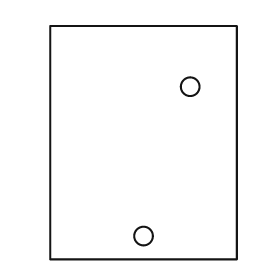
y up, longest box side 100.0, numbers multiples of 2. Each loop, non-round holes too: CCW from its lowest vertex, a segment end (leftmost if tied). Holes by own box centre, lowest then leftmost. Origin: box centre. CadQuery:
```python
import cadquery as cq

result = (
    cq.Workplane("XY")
    .moveTo(-40.0, -50.0)
    .lineTo(40.0, -50.0)
    .lineTo(40.0, 50.0)
    .lineTo(-40.0, 50.0)
    .close()
    .moveTo(0.0, -40.0)
    .circle(4.0)
    .moveTo(20.0, 24.0)
    .circle(4.0)
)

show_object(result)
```